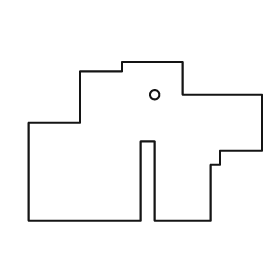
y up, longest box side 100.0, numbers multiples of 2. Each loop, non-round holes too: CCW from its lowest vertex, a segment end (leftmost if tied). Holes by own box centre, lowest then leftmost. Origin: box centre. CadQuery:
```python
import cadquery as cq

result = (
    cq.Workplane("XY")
    .moveTo(-50.0, -34.0)
    .lineTo(-2.0, -34.0)
    .lineTo(-2.0, 0.0)
    .lineTo(4.0, 0.0)
    .lineTo(4.0, -34.0)
    .lineTo(28.0, -34.0)
    .lineTo(28.0, -10.0)
    .lineTo(32.0, -10.0)
    .lineTo(32.0, -4.0)
    .lineTo(50.0, -4.0)
    .lineTo(50.0, 20.0)
    .lineTo(16.0, 20.0)
    .lineTo(16.0, 34.0)
    .lineTo(-10.0, 34.0)
    .lineTo(-10.0, 30.0)
    .lineTo(-28.0, 30.0)
    .lineTo(-28.0, 8.0)
    .lineTo(-50.0, 8.0)
    .close()
    .moveTo(4.0, 20.0)
    .circle(2.0)
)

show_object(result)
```